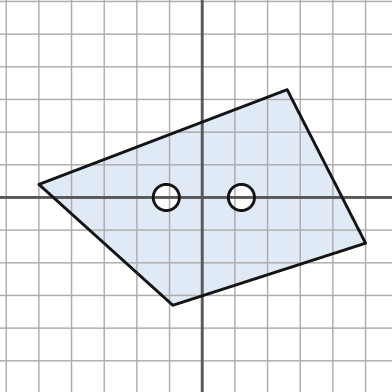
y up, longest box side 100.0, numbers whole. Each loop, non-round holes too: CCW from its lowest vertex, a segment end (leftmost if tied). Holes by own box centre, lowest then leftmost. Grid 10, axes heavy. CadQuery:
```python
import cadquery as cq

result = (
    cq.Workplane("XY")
    .moveTo(-9.0, -33.0)
    .lineTo(50.0, -14.0)
    .lineTo(26.0, 33.0)
    .lineTo(-50.0, 4.0)
    .close()
    .moveTo(-11.0, 0.0)
    .circle(4.0)
    .moveTo(12.0, 0.0)
    .circle(4.0)
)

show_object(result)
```